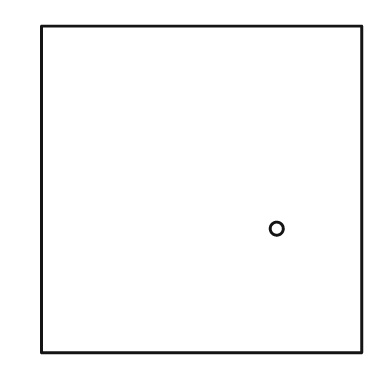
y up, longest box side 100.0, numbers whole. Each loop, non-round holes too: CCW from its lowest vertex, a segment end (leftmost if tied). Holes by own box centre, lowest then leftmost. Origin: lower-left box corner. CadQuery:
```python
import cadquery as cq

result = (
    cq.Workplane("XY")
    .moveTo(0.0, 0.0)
    .lineTo(98.0, 0.0)
    .lineTo(98.0, 100.0)
    .lineTo(0.0, 100.0)
    .close()
    .moveTo(72.0, 38.0)
    .circle(2.0)
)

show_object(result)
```